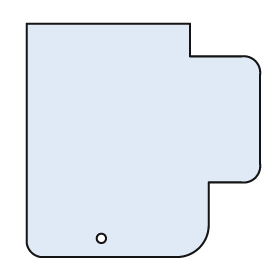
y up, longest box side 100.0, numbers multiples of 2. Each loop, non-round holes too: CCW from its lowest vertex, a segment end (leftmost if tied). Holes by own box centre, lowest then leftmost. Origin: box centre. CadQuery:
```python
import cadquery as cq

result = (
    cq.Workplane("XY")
    .moveTo(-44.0, -50.0)
    .lineTo(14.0, -50.0)
    .threePointArc((24.0, -46.0), (28.0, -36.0))
    .lineTo(28.0, -18.0)
    .lineTo(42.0, -18.0)
    .threePointArc((48.0, -16.0), (50.0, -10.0))
    .lineTo(50.0, 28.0)
    .threePointArc((48.0, 34.0), (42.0, 36.0))
    .lineTo(20.0, 36.0)
    .lineTo(20.0, 50.0)
    .lineTo(-50.0, 50.0)
    .lineTo(-50.0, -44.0)
    .threePointArc((-48.0, -48.0), (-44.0, -50.0))
    .close()
    .moveTo(-18.0, -42.0)
    .circle(2.0)
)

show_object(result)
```